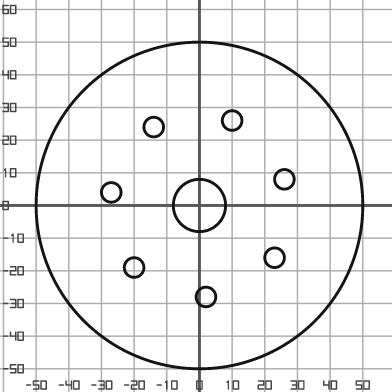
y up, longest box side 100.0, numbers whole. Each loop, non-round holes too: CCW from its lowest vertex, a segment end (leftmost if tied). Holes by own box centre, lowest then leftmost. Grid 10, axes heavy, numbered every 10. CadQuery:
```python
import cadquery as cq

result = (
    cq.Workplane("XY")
    .moveTo(0.0, 0.0)
    .circle(50.0)
    .moveTo(2.0, -28.0)
    .circle(3.0)
    .moveTo(-20.0, -19.0)
    .circle(3.0)
    .moveTo(23.0, -16.0)
    .circle(3.0)
    .moveTo(0.0, 0.0)
    .circle(8.0)
    .moveTo(-27.0, 4.0)
    .circle(3.0)
    .moveTo(26.0, 8.0)
    .circle(3.0)
    .moveTo(-14.0, 24.0)
    .circle(3.0)
    .moveTo(10.0, 26.0)
    .circle(3.0)
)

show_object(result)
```